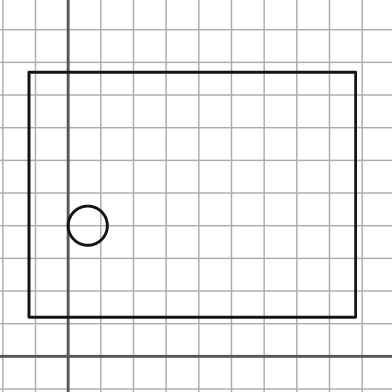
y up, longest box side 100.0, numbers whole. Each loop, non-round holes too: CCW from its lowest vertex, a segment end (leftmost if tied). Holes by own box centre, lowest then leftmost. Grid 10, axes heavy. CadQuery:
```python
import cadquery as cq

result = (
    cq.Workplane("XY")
    .moveTo(-12.0, 12.0)
    .lineTo(88.0, 12.0)
    .lineTo(88.0, 87.0)
    .lineTo(-12.0, 87.0)
    .close()
    .moveTo(6.0, 40.0)
    .circle(6.0)
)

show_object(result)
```